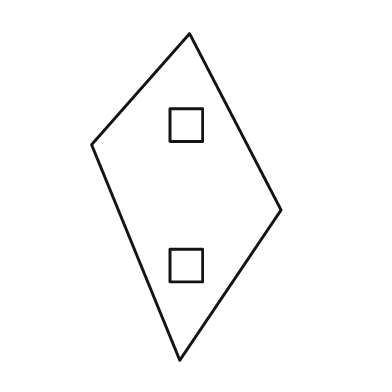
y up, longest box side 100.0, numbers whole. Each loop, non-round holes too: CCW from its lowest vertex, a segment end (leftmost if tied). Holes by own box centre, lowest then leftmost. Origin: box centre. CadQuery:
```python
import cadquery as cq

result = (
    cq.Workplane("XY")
    .moveTo(-2.0, -50.0)
    .lineTo(29.0, -4.0)
    .lineTo(1.0, 50.0)
    .lineTo(-29.0, 16.0)
    .close()
    .moveTo(-5.0, -26.0)
    .lineTo(5.0, -26.0)
    .lineTo(5.0, -16.0)
    .lineTo(-5.0, -16.0)
    .close()
    .moveTo(-5.0, 17.0)
    .lineTo(5.0, 17.0)
    .lineTo(5.0, 27.0)
    .lineTo(-5.0, 27.0)
    .close()
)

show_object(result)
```